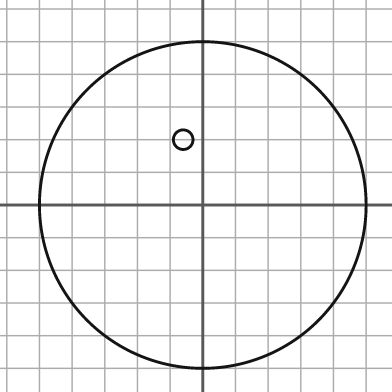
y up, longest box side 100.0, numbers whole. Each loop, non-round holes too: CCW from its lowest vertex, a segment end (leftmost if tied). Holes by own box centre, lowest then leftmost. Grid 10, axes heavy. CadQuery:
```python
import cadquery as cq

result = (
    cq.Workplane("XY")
    .moveTo(0.0, 0.0)
    .circle(50.0)
    .moveTo(-6.0, 20.0)
    .circle(3.0)
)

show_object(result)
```